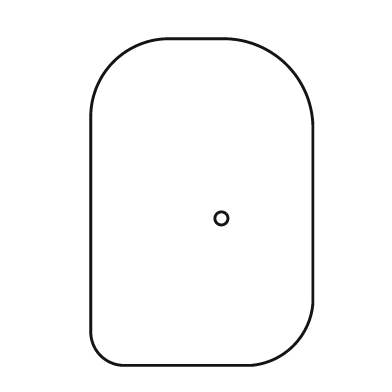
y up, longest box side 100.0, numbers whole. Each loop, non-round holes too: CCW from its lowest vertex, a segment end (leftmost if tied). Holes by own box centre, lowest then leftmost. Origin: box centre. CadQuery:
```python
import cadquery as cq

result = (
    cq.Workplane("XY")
    .moveTo(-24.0, -50.0)
    .lineTo(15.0, -50.0)
    .threePointArc((28.0, -44.0), (34.0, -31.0))
    .lineTo(34.0, 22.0)
    .threePointArc((26.0, 42.0), (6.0, 50.0))
    .lineTo(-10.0, 50.0)
    .threePointArc((-27.0, 43.0), (-34.0, 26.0))
    .lineTo(-34.0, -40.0)
    .threePointArc((-31.0, -47.0), (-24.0, -50.0))
    .close()
    .moveTo(6.0, -5.0)
    .circle(2.0)
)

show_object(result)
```